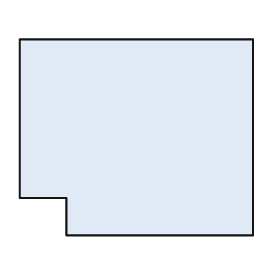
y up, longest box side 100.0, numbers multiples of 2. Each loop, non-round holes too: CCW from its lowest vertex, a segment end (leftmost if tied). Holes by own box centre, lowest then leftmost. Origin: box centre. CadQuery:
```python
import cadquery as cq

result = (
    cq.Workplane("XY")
    .moveTo(-30.0, -42.0)
    .lineTo(50.0, -42.0)
    .lineTo(50.0, 42.0)
    .lineTo(-50.0, 42.0)
    .lineTo(-50.0, -26.0)
    .lineTo(-30.0, -26.0)
    .close()
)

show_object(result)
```